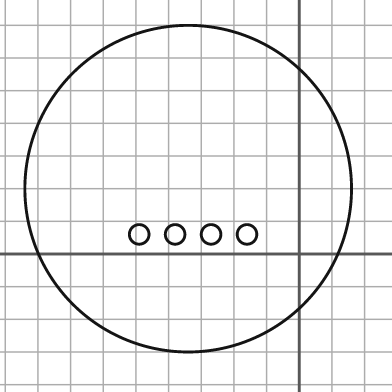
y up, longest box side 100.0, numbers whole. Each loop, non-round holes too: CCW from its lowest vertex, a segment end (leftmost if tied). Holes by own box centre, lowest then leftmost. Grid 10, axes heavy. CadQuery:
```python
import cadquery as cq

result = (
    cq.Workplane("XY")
    .moveTo(-34.0, 20.0)
    .circle(50.0)
    .moveTo(-49.0, 6.0)
    .circle(3.0)
    .moveTo(-38.0, 6.0)
    .circle(3.0)
    .moveTo(-27.0, 6.0)
    .circle(3.0)
    .moveTo(-16.0, 6.0)
    .circle(3.0)
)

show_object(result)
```